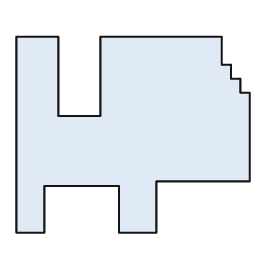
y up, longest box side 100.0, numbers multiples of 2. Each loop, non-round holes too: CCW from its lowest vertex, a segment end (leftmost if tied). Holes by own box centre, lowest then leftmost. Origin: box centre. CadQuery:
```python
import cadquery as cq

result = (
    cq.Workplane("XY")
    .moveTo(-50.0, -42.0)
    .lineTo(-38.0, -42.0)
    .lineTo(-38.0, -22.0)
    .lineTo(-6.0, -22.0)
    .lineTo(-6.0, -42.0)
    .lineTo(10.0, -42.0)
    .lineTo(10.0, -20.0)
    .lineTo(50.0, -20.0)
    .lineTo(50.0, 18.0)
    .lineTo(46.0, 18.0)
    .lineTo(46.0, 24.0)
    .lineTo(42.0, 24.0)
    .lineTo(42.0, 30.0)
    .lineTo(38.0, 30.0)
    .lineTo(38.0, 42.0)
    .lineTo(-14.0, 42.0)
    .lineTo(-14.0, 8.0)
    .lineTo(-32.0, 8.0)
    .lineTo(-32.0, 42.0)
    .lineTo(-50.0, 42.0)
    .close()
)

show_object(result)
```